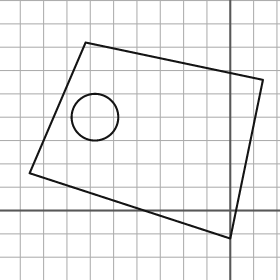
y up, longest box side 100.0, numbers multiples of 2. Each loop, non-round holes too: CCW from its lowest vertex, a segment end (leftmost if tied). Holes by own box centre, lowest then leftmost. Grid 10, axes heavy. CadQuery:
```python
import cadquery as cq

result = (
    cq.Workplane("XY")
    .moveTo(0.0, -12.0)
    .lineTo(14.0, 56.0)
    .lineTo(-62.0, 72.0)
    .lineTo(-86.0, 16.0)
    .close()
    .moveTo(-58.0, 40.0)
    .circle(10.0)
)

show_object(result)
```